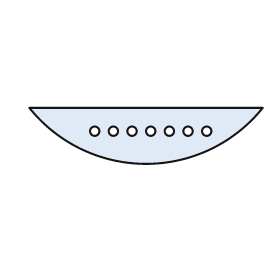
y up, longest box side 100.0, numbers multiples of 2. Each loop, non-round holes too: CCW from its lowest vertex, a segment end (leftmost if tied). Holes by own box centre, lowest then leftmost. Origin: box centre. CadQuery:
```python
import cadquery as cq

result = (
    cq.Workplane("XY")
    .moveTo(-50.0, 12.0)
    .threePointArc((0.0, -12.0), (50.0, 12.0))
    .close()
    .moveTo(-22.0, 2.0)
    .circle(2.0)
    .moveTo(-14.0, 2.0)
    .circle(2.0)
    .moveTo(-6.0, 2.0)
    .circle(2.0)
    .moveTo(2.0, 2.0)
    .circle(2.0)
    .moveTo(10.0, 2.0)
    .circle(2.0)
    .moveTo(18.0, 2.0)
    .circle(2.0)
    .moveTo(26.0, 2.0)
    .circle(2.0)
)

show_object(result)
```